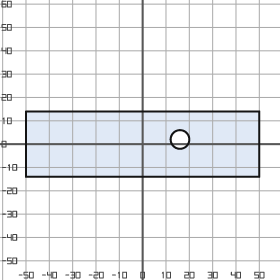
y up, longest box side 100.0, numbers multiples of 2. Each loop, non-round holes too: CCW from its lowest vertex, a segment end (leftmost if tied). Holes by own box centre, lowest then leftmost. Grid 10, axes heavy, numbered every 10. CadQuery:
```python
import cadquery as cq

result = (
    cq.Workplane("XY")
    .moveTo(-50.0, -14.0)
    .lineTo(50.0, -14.0)
    .lineTo(50.0, 14.0)
    .lineTo(-50.0, 14.0)
    .close()
    .moveTo(16.0, 2.0)
    .circle(4.0)
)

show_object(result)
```